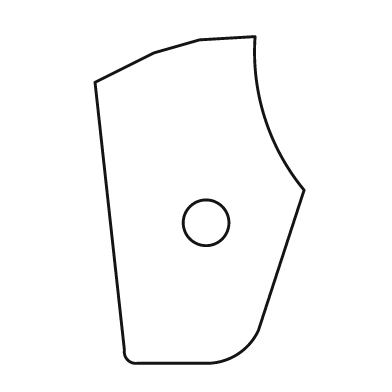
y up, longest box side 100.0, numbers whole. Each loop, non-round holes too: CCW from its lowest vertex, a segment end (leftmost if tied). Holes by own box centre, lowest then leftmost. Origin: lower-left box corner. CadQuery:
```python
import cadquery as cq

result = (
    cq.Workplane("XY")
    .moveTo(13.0, 0.0)
    .lineTo(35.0, 0.0)
    .threePointArc((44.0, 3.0), (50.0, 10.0))
    .lineTo(64.0, 53.0)
    .threePointArc((52.0, 75.0), (49.0, 100.0))
    .lineTo(32.0, 99.0)
    .lineTo(18.0, 95.0)
    .lineTo(0.0, 86.0)
    .lineTo(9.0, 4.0)
    .threePointArc((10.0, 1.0), (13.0, 0.0))
    .close()
    .moveTo(34.0, 43.0)
    .circle(7.0)
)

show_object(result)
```